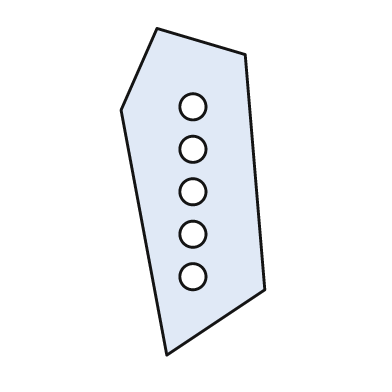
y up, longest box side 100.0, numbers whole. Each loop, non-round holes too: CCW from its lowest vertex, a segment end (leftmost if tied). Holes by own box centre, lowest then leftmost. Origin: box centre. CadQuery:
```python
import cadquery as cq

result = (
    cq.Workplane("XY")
    .moveTo(-8.0, -50.0)
    .lineTo(22.0, -30.0)
    .lineTo(16.0, 42.0)
    .lineTo(-11.0, 50.0)
    .lineTo(-22.0, 25.0)
    .close()
    .moveTo(0.0, -26.0)
    .circle(4.0)
    .moveTo(0.0, -13.0)
    .circle(4.0)
    .moveTo(0.0, 0.0)
    .circle(4.0)
    .moveTo(0.0, 13.0)
    .circle(4.0)
    .moveTo(0.0, 26.0)
    .circle(4.0)
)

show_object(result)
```